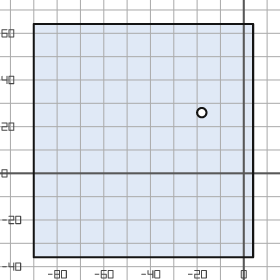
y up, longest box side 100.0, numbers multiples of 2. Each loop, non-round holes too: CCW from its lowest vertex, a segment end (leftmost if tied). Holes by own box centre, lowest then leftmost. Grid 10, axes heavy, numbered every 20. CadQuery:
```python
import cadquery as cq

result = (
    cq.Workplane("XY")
    .moveTo(-90.0, -36.0)
    .lineTo(4.0, -36.0)
    .lineTo(4.0, 64.0)
    .lineTo(-90.0, 64.0)
    .close()
    .moveTo(-18.0, 26.0)
    .circle(2.0)
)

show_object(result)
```